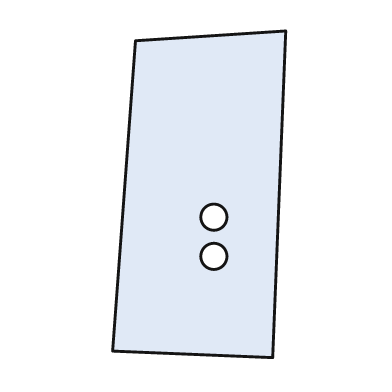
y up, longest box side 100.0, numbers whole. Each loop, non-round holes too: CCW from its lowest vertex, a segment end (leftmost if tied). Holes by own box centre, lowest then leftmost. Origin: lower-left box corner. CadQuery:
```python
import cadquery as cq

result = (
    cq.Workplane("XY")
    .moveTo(49.0, 0.0)
    .lineTo(53.0, 100.0)
    .lineTo(7.0, 97.0)
    .lineTo(0.0, 2.0)
    .close()
    .moveTo(31.0, 31.0)
    .circle(4.0)
    .moveTo(31.0, 43.0)
    .circle(4.0)
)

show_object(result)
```